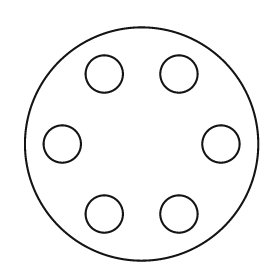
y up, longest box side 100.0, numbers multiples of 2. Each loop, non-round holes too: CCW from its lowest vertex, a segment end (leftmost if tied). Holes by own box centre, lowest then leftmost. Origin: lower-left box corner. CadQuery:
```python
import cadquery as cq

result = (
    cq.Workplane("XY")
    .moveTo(50.0, 50.0)
    .circle(50.0)
    .moveTo(34.0, 20.0)
    .circle(8.0)
    .moveTo(66.0, 20.0)
    .circle(8.0)
    .moveTo(16.0, 50.0)
    .circle(8.0)
    .moveTo(84.0, 50.0)
    .circle(8.0)
    .moveTo(34.0, 80.0)
    .circle(8.0)
    .moveTo(66.0, 80.0)
    .circle(8.0)
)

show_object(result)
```